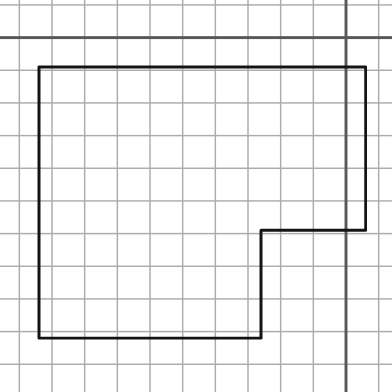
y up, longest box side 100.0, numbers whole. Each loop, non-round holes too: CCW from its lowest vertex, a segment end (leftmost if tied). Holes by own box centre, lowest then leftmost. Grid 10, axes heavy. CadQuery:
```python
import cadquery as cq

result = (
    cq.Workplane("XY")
    .moveTo(-94.0, -92.0)
    .lineTo(-26.0, -92.0)
    .lineTo(-26.0, -59.0)
    .lineTo(6.0, -59.0)
    .lineTo(6.0, -9.0)
    .lineTo(-94.0, -9.0)
    .close()
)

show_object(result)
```